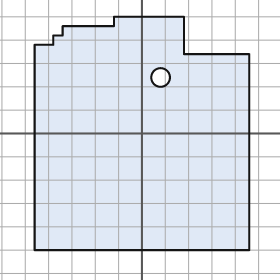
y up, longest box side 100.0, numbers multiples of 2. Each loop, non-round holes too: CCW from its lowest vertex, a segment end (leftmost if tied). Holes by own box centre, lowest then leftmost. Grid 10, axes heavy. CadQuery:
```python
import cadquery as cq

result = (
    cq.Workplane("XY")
    .moveTo(-46.0, -50.0)
    .lineTo(46.0, -50.0)
    .lineTo(46.0, 34.0)
    .lineTo(18.0, 34.0)
    .lineTo(18.0, 50.0)
    .lineTo(-12.0, 50.0)
    .lineTo(-12.0, 46.0)
    .lineTo(-34.0, 46.0)
    .lineTo(-34.0, 42.0)
    .lineTo(-38.0, 42.0)
    .lineTo(-38.0, 38.0)
    .lineTo(-46.0, 38.0)
    .close()
    .moveTo(8.0, 24.0)
    .circle(4.0)
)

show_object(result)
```